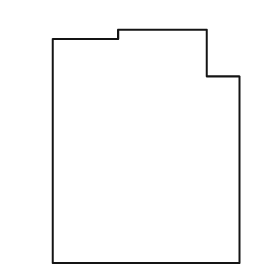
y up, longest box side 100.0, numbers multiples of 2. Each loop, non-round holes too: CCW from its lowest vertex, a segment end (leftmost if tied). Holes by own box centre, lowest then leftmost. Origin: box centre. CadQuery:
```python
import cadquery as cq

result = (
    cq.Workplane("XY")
    .moveTo(-40.0, -50.0)
    .lineTo(40.0, -50.0)
    .lineTo(40.0, 30.0)
    .lineTo(26.0, 30.0)
    .lineTo(26.0, 50.0)
    .lineTo(-12.0, 50.0)
    .lineTo(-12.0, 46.0)
    .lineTo(-40.0, 46.0)
    .close()
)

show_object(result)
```